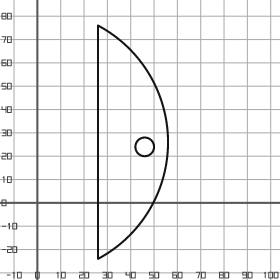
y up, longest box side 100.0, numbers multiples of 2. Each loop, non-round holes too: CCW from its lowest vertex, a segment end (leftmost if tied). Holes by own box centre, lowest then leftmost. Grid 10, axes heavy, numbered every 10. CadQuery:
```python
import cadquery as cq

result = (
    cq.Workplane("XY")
    .moveTo(26.0, -24.0)
    .threePointArc((56.0, 26.0), (26.0, 76.0))
    .close()
    .moveTo(46.0, 24.0)
    .circle(4.0)
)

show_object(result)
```